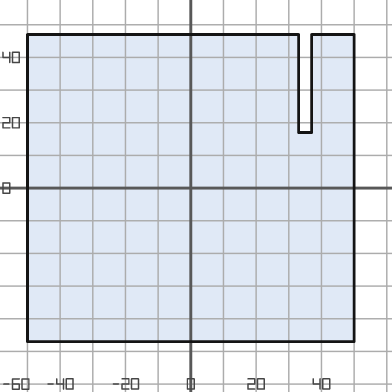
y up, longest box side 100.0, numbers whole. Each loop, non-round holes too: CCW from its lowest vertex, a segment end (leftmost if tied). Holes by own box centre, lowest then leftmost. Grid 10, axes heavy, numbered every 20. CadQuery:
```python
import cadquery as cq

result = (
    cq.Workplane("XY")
    .moveTo(-50.0, -47.0)
    .lineTo(50.0, -47.0)
    .lineTo(50.0, 47.0)
    .lineTo(37.0, 47.0)
    .lineTo(37.0, 17.0)
    .lineTo(33.0, 17.0)
    .lineTo(33.0, 47.0)
    .lineTo(-50.0, 47.0)
    .close()
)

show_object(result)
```